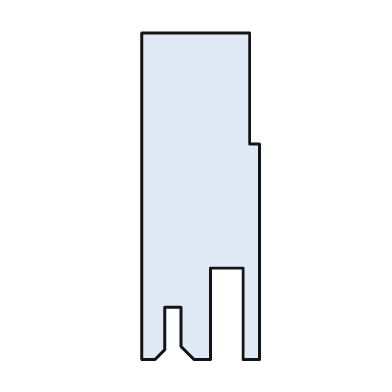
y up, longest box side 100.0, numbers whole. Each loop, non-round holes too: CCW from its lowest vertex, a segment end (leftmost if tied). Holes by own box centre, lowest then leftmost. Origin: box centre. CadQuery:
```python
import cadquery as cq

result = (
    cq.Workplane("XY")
    .moveTo(-18.0, -50.0)
    .lineTo(-14.0, -50.0)
    .lineTo(-11.0, -47.0)
    .lineTo(-11.0, -34.0)
    .lineTo(-6.0, -34.0)
    .lineTo(-6.0, -46.0)
    .lineTo(-2.0, -50.0)
    .lineTo(3.0, -50.0)
    .lineTo(3.0, -22.0)
    .lineTo(13.0, -22.0)
    .lineTo(13.0, -50.0)
    .lineTo(18.0, -50.0)
    .lineTo(18.0, 16.0)
    .lineTo(15.0, 16.0)
    .lineTo(15.0, 50.0)
    .lineTo(-18.0, 50.0)
    .close()
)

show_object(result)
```